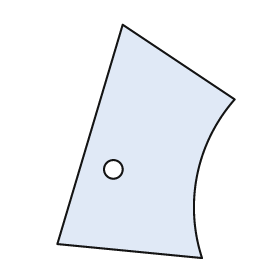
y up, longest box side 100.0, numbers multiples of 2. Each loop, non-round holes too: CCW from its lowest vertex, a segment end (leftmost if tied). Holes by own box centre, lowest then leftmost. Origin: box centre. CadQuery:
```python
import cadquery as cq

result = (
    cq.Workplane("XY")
    .moveTo(24.0, -50.0)
    .threePointArc((22.0, -14.0), (38.0, 18.0))
    .lineTo(-10.0, 50.0)
    .lineTo(-38.0, -44.0)
    .close()
    .moveTo(-14.0, -12.0)
    .circle(4.0)
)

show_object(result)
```